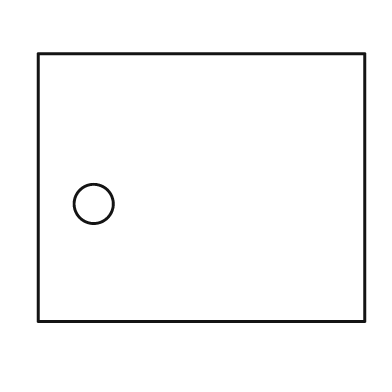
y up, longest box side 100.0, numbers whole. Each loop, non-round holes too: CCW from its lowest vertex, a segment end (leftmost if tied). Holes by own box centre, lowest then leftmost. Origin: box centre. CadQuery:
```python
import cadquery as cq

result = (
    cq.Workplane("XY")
    .moveTo(-50.0, -41.0)
    .lineTo(50.0, -41.0)
    .lineTo(50.0, 41.0)
    .lineTo(-50.0, 41.0)
    .close()
    .moveTo(-33.0, -5.0)
    .circle(6.0)
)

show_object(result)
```